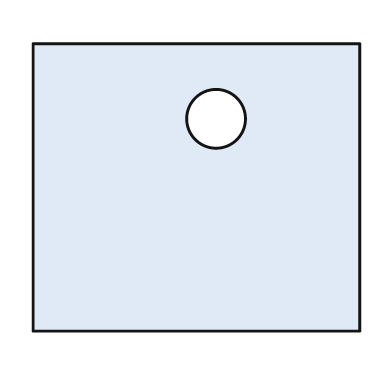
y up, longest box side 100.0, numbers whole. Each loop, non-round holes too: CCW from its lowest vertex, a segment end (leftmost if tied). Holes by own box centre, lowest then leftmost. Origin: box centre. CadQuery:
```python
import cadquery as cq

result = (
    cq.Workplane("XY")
    .moveTo(-50.0, -44.0)
    .lineTo(50.0, -44.0)
    .lineTo(50.0, 44.0)
    .lineTo(-50.0, 44.0)
    .close()
    .moveTo(6.0, 21.0)
    .circle(9.0)
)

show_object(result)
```